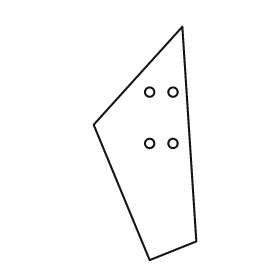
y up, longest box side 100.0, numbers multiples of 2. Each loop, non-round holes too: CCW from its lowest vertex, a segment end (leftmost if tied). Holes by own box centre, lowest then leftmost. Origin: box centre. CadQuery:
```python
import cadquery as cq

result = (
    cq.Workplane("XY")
    .moveTo(2.0, -50.0)
    .lineTo(22.0, -42.0)
    .lineTo(16.0, 50.0)
    .lineTo(-22.0, 8.0)
    .close()
    .moveTo(2.0, 0.0)
    .circle(2.0)
    .moveTo(12.0, 0.0)
    .circle(2.0)
    .moveTo(2.0, 22.0)
    .circle(2.0)
    .moveTo(12.0, 22.0)
    .circle(2.0)
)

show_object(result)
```